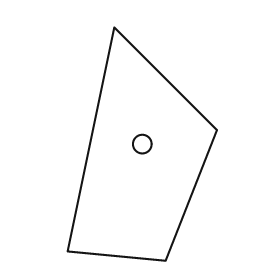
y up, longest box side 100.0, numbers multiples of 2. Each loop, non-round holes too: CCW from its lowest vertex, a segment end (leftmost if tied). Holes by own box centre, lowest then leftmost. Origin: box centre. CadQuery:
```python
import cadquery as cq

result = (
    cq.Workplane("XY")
    .moveTo(10.0, -50.0)
    .lineTo(32.0, 6.0)
    .lineTo(-12.0, 50.0)
    .lineTo(-32.0, -46.0)
    .close()
    .moveTo(0.0, 0.0)
    .circle(4.0)
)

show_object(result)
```